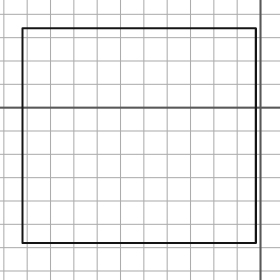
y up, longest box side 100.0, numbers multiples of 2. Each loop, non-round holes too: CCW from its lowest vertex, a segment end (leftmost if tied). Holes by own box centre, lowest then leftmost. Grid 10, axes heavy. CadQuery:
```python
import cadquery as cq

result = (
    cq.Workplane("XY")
    .moveTo(-102.0, -58.0)
    .lineTo(-2.0, -58.0)
    .lineTo(-2.0, 34.0)
    .lineTo(-102.0, 34.0)
    .close()
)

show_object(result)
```